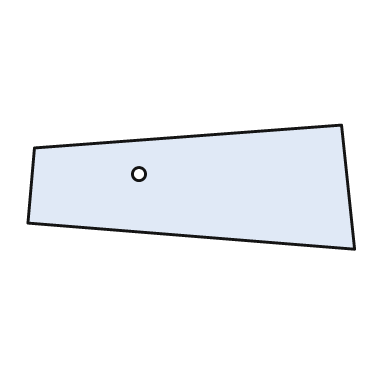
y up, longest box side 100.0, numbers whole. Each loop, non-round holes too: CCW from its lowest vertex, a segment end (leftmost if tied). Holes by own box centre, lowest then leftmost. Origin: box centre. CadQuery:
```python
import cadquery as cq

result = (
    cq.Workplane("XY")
    .moveTo(50.0, -19.0)
    .lineTo(46.0, 19.0)
    .lineTo(-48.0, 12.0)
    .lineTo(-50.0, -11.0)
    .close()
    .moveTo(-16.0, 4.0)
    .circle(2.0)
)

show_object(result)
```